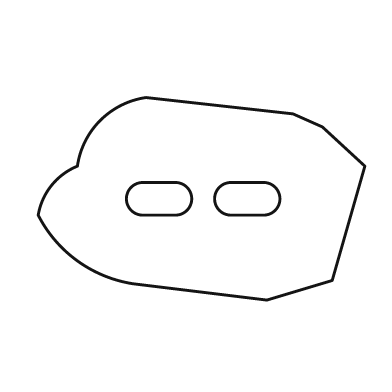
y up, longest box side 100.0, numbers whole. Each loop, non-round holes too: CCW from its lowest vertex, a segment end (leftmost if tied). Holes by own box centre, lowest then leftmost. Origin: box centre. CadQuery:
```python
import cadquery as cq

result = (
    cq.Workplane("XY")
    .moveTo(20.0, -31.0)
    .lineTo(40.0, -25.0)
    .lineTo(50.0, 10.0)
    .lineTo(37.0, 22.0)
    .lineTo(28.0, 26.0)
    .lineTo(-17.0, 31.0)
    .threePointArc((-31.0, 24.0), (-38.0, 10.0))
    .threePointArc((-46.0, 4.0), (-50.0, -5.0))
    .threePointArc((-38.0, -19.0), (-21.0, -26.0))
    .close()
    .moveTo(-18.0, -5.0)
    .lineTo(-8.0, -5.0)
    .threePointArc((-3.0, 0.0), (-8.0, 5.0))
    .lineTo(-18.0, 5.0)
    .threePointArc((-23.0, 0.0), (-18.0, -5.0))
    .close()
    .moveTo(9.0, -5.0)
    .lineTo(19.0, -5.0)
    .threePointArc((24.0, 0.0), (19.0, 5.0))
    .lineTo(9.0, 5.0)
    .threePointArc((4.0, 0.0), (9.0, -5.0))
    .close()
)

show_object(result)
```